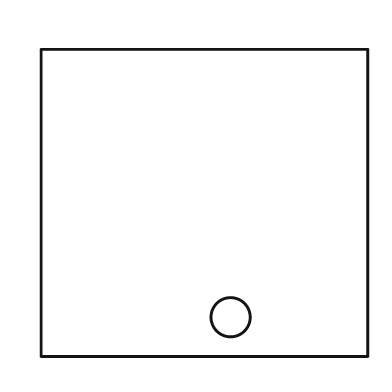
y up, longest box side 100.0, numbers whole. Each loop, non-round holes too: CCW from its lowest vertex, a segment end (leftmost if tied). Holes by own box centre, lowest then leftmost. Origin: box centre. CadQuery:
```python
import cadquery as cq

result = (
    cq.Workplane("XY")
    .moveTo(-50.0, -47.0)
    .lineTo(50.0, -47.0)
    .lineTo(50.0, 47.0)
    .lineTo(-50.0, 47.0)
    .close()
    .moveTo(8.0, -35.0)
    .circle(6.0)
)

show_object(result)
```